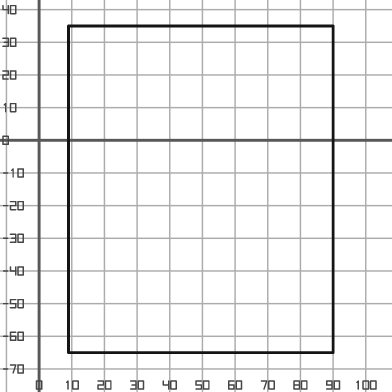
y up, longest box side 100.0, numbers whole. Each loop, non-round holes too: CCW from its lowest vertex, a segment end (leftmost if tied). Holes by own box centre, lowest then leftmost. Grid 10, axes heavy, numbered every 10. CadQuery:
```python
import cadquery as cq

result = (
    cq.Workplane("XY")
    .moveTo(9.0, -65.0)
    .lineTo(90.0, -65.0)
    .lineTo(90.0, 35.0)
    .lineTo(9.0, 35.0)
    .close()
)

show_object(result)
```